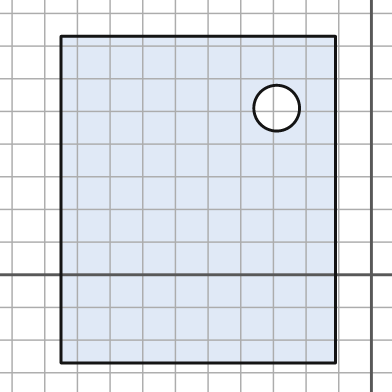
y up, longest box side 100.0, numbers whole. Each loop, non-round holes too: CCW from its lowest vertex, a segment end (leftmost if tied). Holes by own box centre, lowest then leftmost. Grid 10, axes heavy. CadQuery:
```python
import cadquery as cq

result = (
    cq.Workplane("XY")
    .moveTo(-95.0, -27.0)
    .lineTo(-11.0, -27.0)
    .lineTo(-11.0, 73.0)
    .lineTo(-95.0, 73.0)
    .close()
    .moveTo(-29.0, 51.0)
    .circle(7.0)
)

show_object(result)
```